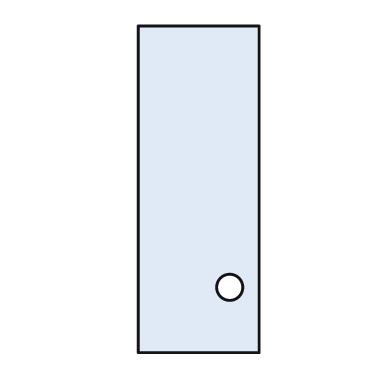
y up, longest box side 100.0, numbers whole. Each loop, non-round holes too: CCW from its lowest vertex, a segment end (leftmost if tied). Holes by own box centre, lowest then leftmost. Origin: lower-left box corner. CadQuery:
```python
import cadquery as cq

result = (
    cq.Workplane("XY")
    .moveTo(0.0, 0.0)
    .lineTo(37.0, 0.0)
    .lineTo(37.0, 100.0)
    .lineTo(0.0, 100.0)
    .close()
    .moveTo(28.0, 20.0)
    .circle(4.0)
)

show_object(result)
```